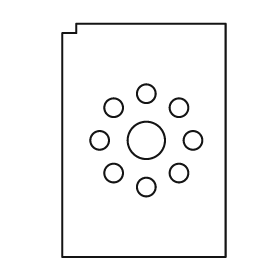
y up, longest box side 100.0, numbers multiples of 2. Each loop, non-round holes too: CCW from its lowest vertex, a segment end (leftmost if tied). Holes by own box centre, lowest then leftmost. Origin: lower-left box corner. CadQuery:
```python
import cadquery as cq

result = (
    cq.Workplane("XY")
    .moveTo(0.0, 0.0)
    .lineTo(70.0, 0.0)
    .lineTo(70.0, 100.0)
    .lineTo(6.0, 100.0)
    .lineTo(6.0, 96.0)
    .lineTo(0.0, 96.0)
    .close()
    .moveTo(36.0, 30.0)
    .circle(4.0)
    .moveTo(22.0, 36.0)
    .circle(4.0)
    .moveTo(50.0, 36.0)
    .circle(4.0)
    .moveTo(16.0, 50.0)
    .circle(4.0)
    .moveTo(36.0, 50.0)
    .circle(8.0)
    .moveTo(56.0, 50.0)
    .circle(4.0)
    .moveTo(22.0, 64.0)
    .circle(4.0)
    .moveTo(50.0, 64.0)
    .circle(4.0)
    .moveTo(36.0, 70.0)
    .circle(4.0)
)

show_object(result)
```